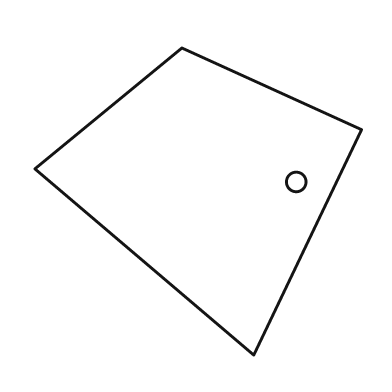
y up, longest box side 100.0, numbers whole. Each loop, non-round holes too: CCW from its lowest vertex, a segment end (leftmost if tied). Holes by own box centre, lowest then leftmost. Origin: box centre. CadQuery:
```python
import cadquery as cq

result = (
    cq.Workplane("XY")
    .moveTo(17.0, -47.0)
    .lineTo(50.0, 22.0)
    .lineTo(-5.0, 47.0)
    .lineTo(-50.0, 10.0)
    .close()
    .moveTo(30.0, 6.0)
    .circle(3.0)
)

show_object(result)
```